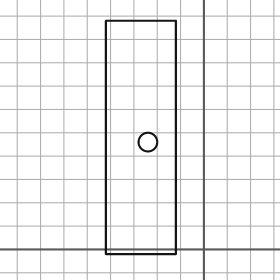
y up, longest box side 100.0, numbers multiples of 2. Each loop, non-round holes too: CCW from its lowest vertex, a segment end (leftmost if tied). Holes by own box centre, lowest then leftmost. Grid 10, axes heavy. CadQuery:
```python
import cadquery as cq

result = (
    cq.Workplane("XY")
    .moveTo(-42.0, -2.0)
    .lineTo(-12.0, -2.0)
    .lineTo(-12.0, 98.0)
    .lineTo(-42.0, 98.0)
    .close()
    .moveTo(-24.0, 46.0)
    .circle(4.0)
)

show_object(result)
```